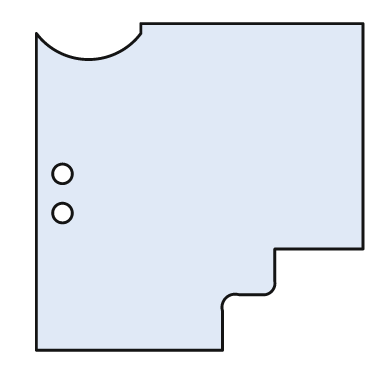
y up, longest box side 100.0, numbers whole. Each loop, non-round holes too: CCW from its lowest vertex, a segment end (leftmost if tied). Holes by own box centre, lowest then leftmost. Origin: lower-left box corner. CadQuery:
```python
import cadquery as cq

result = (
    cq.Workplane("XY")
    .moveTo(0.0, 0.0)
    .lineTo(57.0, 0.0)
    .lineTo(57.0, 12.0)
    .threePointArc((58.0, 16.0), (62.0, 17.0))
    .lineTo(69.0, 17.0)
    .threePointArc((72.0, 18.0), (73.0, 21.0))
    .lineTo(73.0, 31.0)
    .lineTo(100.0, 31.0)
    .lineTo(100.0, 100.0)
    .lineTo(32.0, 100.0)
    .lineTo(32.0, 97.0)
    .threePointArc((16.0, 89.0), (0.0, 97.0))
    .close()
    .moveTo(8.0, 42.0)
    .circle(3.0)
    .moveTo(8.0, 54.0)
    .circle(3.0)
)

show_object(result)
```